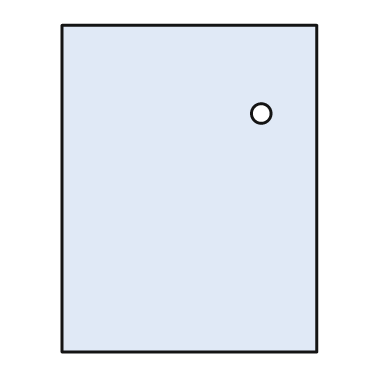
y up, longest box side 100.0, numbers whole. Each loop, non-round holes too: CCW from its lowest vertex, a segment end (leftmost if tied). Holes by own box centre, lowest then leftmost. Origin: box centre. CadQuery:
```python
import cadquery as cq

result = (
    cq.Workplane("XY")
    .moveTo(-39.0, -50.0)
    .lineTo(39.0, -50.0)
    .lineTo(39.0, 50.0)
    .lineTo(-39.0, 50.0)
    .close()
    .moveTo(22.0, 23.0)
    .circle(3.0)
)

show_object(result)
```